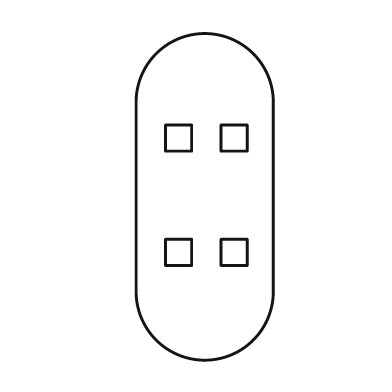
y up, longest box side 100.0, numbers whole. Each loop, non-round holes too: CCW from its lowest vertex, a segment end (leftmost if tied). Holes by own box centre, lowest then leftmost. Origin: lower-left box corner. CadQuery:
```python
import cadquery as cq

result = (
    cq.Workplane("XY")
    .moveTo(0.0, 21.0)
    .threePointArc((21.0, 0.0), (42.0, 21.0))
    .lineTo(42.0, 79.0)
    .threePointArc((21.0, 100.0), (0.0, 79.0))
    .close()
    .moveTo(9.0, 29.0)
    .lineTo(17.0, 29.0)
    .lineTo(17.0, 37.0)
    .lineTo(9.0, 37.0)
    .close()
    .moveTo(26.0, 29.0)
    .lineTo(34.0, 29.0)
    .lineTo(34.0, 37.0)
    .lineTo(26.0, 37.0)
    .close()
    .moveTo(9.0, 64.0)
    .lineTo(17.0, 64.0)
    .lineTo(17.0, 72.0)
    .lineTo(9.0, 72.0)
    .close()
    .moveTo(26.0, 64.0)
    .lineTo(34.0, 64.0)
    .lineTo(34.0, 72.0)
    .lineTo(26.0, 72.0)
    .close()
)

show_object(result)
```